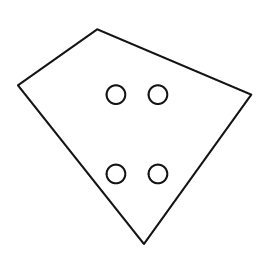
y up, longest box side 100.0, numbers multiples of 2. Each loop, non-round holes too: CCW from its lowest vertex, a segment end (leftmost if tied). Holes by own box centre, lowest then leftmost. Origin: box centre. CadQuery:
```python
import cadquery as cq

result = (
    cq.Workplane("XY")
    .moveTo(4.0, -46.0)
    .lineTo(50.0, 18.0)
    .lineTo(-16.0, 46.0)
    .lineTo(-50.0, 22.0)
    .close()
    .moveTo(-8.0, -16.0)
    .circle(4.0)
    .moveTo(10.0, -16.0)
    .circle(4.0)
    .moveTo(-8.0, 18.0)
    .circle(4.0)
    .moveTo(10.0, 18.0)
    .circle(4.0)
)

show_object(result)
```